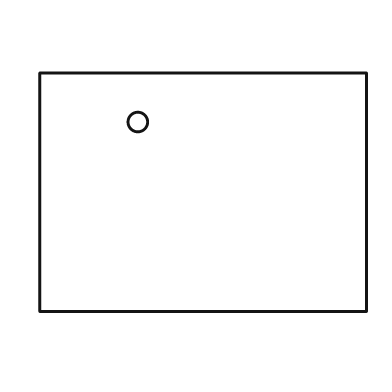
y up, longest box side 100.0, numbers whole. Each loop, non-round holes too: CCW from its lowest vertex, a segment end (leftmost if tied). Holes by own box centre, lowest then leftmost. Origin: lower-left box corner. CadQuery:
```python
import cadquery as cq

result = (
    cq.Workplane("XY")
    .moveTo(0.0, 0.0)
    .lineTo(100.0, 0.0)
    .lineTo(100.0, 73.0)
    .lineTo(0.0, 73.0)
    .close()
    .moveTo(30.0, 58.0)
    .circle(3.0)
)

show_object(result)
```